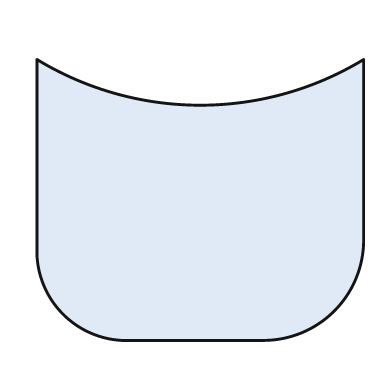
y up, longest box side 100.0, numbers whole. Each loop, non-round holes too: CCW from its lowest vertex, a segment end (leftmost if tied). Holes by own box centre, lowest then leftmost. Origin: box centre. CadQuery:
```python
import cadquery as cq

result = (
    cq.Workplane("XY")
    .moveTo(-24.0, -43.0)
    .lineTo(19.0, -43.0)
    .threePointArc((41.0, -34.0), (50.0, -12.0))
    .lineTo(50.0, 43.0)
    .threePointArc((0.0, 29.0), (-50.0, 43.0))
    .lineTo(-50.0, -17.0)
    .threePointArc((-42.0, -35.0), (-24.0, -43.0))
    .close()
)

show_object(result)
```